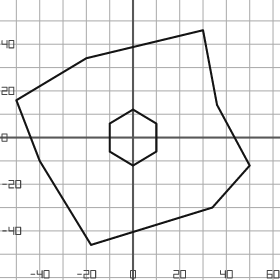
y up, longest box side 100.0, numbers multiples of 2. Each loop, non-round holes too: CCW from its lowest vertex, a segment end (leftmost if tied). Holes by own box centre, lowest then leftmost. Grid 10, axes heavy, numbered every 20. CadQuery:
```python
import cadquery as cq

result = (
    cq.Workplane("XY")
    .moveTo(-18.0, -46.0)
    .lineTo(34.0, -30.0)
    .lineTo(50.0, -12.0)
    .lineTo(36.0, 14.0)
    .lineTo(30.0, 46.0)
    .lineTo(-20.0, 34.0)
    .lineTo(-50.0, 16.0)
    .lineTo(-40.0, -10.0)
    .close()
    .moveTo(0.0, -12.0)
    .lineTo(10.0, -6.0)
    .lineTo(10.0, 6.0)
    .lineTo(0.0, 12.0)
    .lineTo(-10.0, 6.0)
    .lineTo(-10.0, -6.0)
    .close()
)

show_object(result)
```